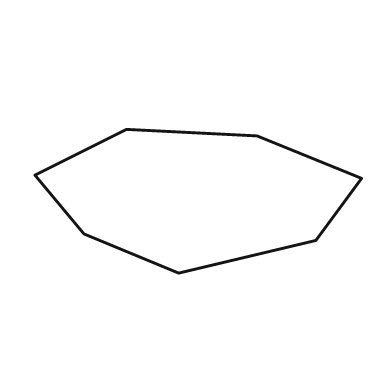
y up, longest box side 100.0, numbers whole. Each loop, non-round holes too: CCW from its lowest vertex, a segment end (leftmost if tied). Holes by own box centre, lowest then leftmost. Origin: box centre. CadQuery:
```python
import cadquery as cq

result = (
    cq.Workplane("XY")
    .moveTo(-6.0, -22.0)
    .lineTo(36.0, -12.0)
    .lineTo(50.0, 7.0)
    .lineTo(18.0, 20.0)
    .lineTo(-22.0, 22.0)
    .lineTo(-50.0, 8.0)
    .lineTo(-35.0, -10.0)
    .close()
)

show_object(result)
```